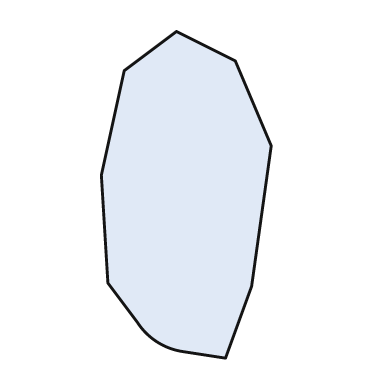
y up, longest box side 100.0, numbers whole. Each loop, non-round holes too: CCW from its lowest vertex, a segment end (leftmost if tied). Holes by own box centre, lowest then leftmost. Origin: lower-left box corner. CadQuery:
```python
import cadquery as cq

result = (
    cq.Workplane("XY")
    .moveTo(38.0, 0.0)
    .lineTo(46.0, 22.0)
    .lineTo(52.0, 65.0)
    .lineTo(41.0, 91.0)
    .lineTo(23.0, 100.0)
    .lineTo(7.0, 88.0)
    .lineTo(0.0, 56.0)
    .lineTo(2.0, 23.0)
    .lineTo(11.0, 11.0)
    .threePointArc((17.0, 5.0), (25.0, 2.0))
    .close()
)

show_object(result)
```